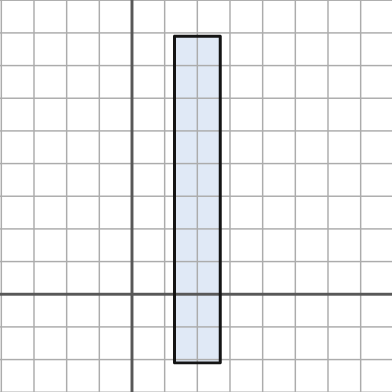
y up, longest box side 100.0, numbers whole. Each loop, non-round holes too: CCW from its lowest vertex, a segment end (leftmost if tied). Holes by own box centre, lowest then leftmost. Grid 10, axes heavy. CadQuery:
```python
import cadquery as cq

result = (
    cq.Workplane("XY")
    .moveTo(13.0, -21.0)
    .lineTo(27.0, -21.0)
    .lineTo(27.0, 79.0)
    .lineTo(13.0, 79.0)
    .close()
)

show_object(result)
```